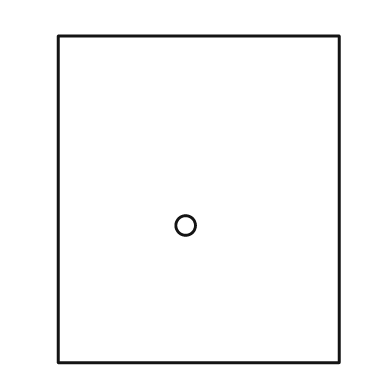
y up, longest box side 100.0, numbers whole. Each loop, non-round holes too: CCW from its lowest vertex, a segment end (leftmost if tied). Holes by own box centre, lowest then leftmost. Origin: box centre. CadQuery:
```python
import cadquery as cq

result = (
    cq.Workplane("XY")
    .moveTo(-43.0, -50.0)
    .lineTo(43.0, -50.0)
    .lineTo(43.0, 50.0)
    .lineTo(-43.0, 50.0)
    .close()
    .moveTo(-4.0, -8.0)
    .circle(3.0)
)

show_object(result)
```